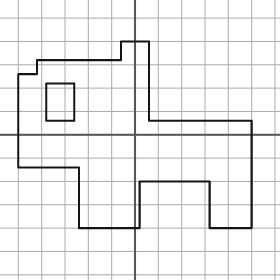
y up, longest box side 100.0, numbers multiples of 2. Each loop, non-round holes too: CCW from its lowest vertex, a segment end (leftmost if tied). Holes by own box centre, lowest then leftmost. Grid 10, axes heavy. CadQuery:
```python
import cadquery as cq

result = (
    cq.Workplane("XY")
    .moveTo(-24.0, -40.0)
    .lineTo(2.0, -40.0)
    .lineTo(2.0, -20.0)
    .lineTo(32.0, -20.0)
    .lineTo(32.0, -40.0)
    .lineTo(50.0, -40.0)
    .lineTo(50.0, 6.0)
    .lineTo(6.0, 6.0)
    .lineTo(6.0, 40.0)
    .lineTo(-6.0, 40.0)
    .lineTo(-6.0, 32.0)
    .lineTo(-42.0, 32.0)
    .lineTo(-42.0, 26.0)
    .lineTo(-50.0, 26.0)
    .lineTo(-50.0, -14.0)
    .lineTo(-24.0, -14.0)
    .close()
    .moveTo(-38.0, 6.0)
    .lineTo(-26.0, 6.0)
    .lineTo(-26.0, 22.0)
    .lineTo(-38.0, 22.0)
    .close()
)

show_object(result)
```